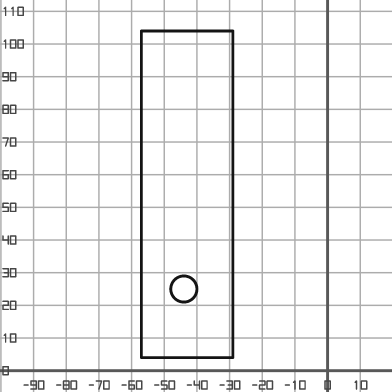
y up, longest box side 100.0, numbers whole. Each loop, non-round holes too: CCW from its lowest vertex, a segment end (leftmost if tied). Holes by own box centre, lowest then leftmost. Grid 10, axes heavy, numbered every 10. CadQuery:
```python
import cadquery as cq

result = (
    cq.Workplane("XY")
    .moveTo(-57.0, 4.0)
    .lineTo(-29.0, 4.0)
    .lineTo(-29.0, 104.0)
    .lineTo(-57.0, 104.0)
    .close()
    .moveTo(-44.0, 25.0)
    .circle(4.0)
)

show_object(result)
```